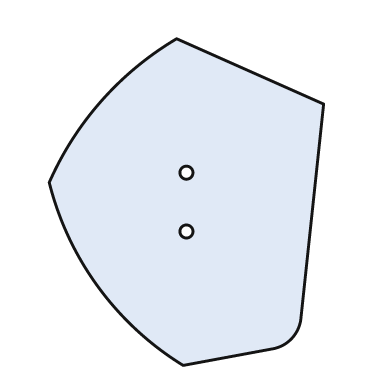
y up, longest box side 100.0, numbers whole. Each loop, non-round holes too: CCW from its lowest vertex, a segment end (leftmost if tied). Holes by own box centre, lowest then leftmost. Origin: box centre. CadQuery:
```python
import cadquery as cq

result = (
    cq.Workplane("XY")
    .moveTo(-1.0, -50.0)
    .lineTo(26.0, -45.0)
    .threePointArc((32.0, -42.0), (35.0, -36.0))
    .lineTo(42.0, 30.0)
    .lineTo(-3.0, 50.0)
    .threePointArc((-26.0, 31.0), (-42.0, 6.0))
    .threePointArc((-27.0, -26.0), (-1.0, -50.0))
    .close()
    .moveTo(0.0, -9.0)
    .circle(2.0)
    .moveTo(0.0, 9.0)
    .circle(2.0)
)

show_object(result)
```